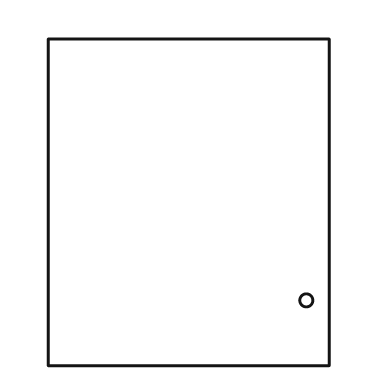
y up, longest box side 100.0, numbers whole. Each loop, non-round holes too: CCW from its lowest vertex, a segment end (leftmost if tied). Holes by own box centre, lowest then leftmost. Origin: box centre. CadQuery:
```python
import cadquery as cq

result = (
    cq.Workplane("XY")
    .moveTo(-43.0, -50.0)
    .lineTo(43.0, -50.0)
    .lineTo(43.0, 50.0)
    .lineTo(-43.0, 50.0)
    .close()
    .moveTo(36.0, -30.0)
    .circle(2.0)
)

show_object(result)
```